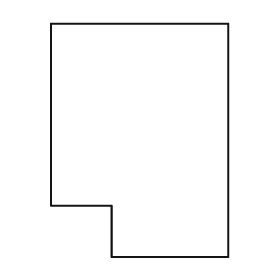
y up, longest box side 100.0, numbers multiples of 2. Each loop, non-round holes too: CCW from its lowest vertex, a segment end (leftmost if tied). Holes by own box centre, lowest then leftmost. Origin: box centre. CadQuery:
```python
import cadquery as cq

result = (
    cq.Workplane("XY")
    .moveTo(-12.0, -50.0)
    .lineTo(38.0, -50.0)
    .lineTo(38.0, 50.0)
    .lineTo(-38.0, 50.0)
    .lineTo(-38.0, -28.0)
    .lineTo(-12.0, -28.0)
    .close()
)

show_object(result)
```